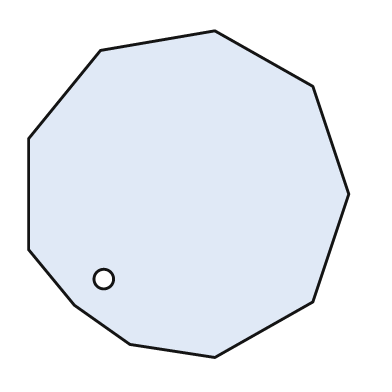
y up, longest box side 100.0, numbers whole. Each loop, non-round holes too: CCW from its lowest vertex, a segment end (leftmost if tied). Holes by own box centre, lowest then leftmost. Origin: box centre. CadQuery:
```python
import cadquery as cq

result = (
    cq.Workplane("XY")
    .moveTo(8.0, -50.0)
    .lineTo(38.0, -33.0)
    .lineTo(49.0, 0.0)
    .lineTo(38.0, 33.0)
    .lineTo(8.0, 50.0)
    .lineTo(-27.0, 44.0)
    .lineTo(-49.0, 17.0)
    .lineTo(-49.0, -17.0)
    .lineTo(-35.0, -34.0)
    .lineTo(-18.0, -46.0)
    .close()
    .moveTo(-26.0, -26.0)
    .circle(3.0)
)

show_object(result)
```